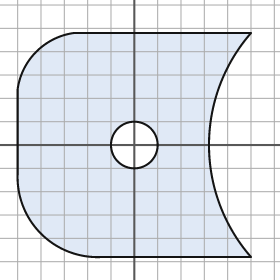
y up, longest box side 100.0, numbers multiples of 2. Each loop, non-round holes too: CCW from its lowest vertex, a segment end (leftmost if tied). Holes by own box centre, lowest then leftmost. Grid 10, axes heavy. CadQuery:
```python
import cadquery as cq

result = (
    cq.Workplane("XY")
    .moveTo(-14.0, -48.0)
    .lineTo(50.0, -48.0)
    .threePointArc((32.0, 0.0), (50.0, 48.0))
    .lineTo(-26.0, 48.0)
    .threePointArc((-42.0, 40.0), (-50.0, 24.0))
    .lineTo(-50.0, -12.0)
    .threePointArc((-40.0, -38.0), (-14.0, -48.0))
    .close()
    .moveTo(0.0, 0.0)
    .circle(10.0)
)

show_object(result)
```